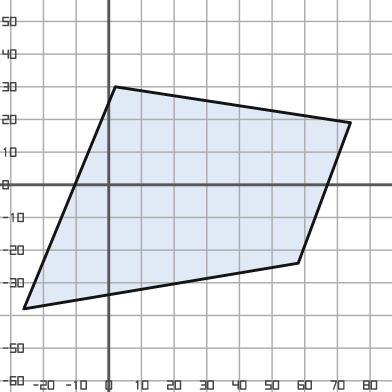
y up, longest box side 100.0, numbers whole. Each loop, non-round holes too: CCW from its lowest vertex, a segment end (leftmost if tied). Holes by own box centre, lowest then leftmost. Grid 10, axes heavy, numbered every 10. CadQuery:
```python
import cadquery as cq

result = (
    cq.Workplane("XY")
    .moveTo(-26.0, -38.0)
    .lineTo(58.0, -24.0)
    .lineTo(74.0, 19.0)
    .lineTo(2.0, 30.0)
    .close()
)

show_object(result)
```